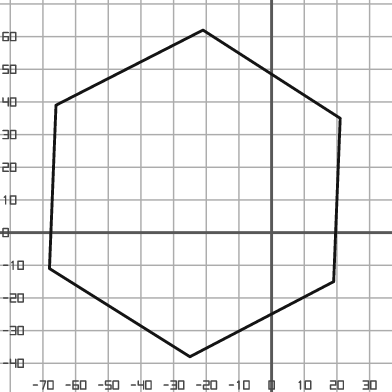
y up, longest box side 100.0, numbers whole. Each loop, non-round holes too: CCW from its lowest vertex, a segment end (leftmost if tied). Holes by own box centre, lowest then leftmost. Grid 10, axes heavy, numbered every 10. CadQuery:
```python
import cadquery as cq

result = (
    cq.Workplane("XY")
    .moveTo(-25.0, -38.0)
    .lineTo(19.0, -15.0)
    .lineTo(21.0, 35.0)
    .lineTo(-21.0, 62.0)
    .lineTo(-66.0, 39.0)
    .lineTo(-68.0, -11.0)
    .close()
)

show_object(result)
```